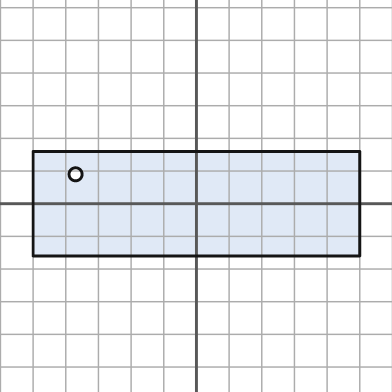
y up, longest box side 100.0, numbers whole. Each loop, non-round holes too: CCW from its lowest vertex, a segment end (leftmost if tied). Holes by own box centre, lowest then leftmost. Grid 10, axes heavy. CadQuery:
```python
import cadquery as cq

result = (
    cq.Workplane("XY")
    .moveTo(-50.0, -16.0)
    .lineTo(50.0, -16.0)
    .lineTo(50.0, 16.0)
    .lineTo(-50.0, 16.0)
    .close()
    .moveTo(-37.0, 9.0)
    .circle(2.0)
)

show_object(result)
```